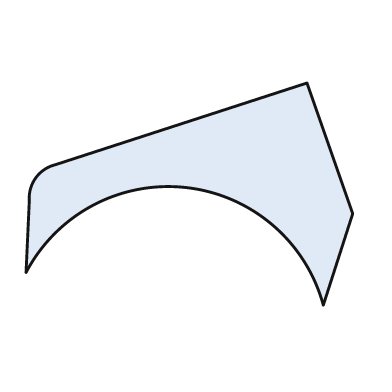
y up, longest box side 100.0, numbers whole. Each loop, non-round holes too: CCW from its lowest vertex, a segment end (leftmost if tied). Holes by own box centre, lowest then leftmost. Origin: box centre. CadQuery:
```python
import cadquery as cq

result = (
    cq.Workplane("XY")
    .moveTo(41.0, -34.0)
    .lineTo(50.0, -6.0)
    .lineTo(36.0, 34.0)
    .lineTo(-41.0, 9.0)
    .threePointArc((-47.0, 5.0), (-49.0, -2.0))
    .lineTo(-50.0, -24.0)
    .threePointArc((-1.0, 2.0), (41.0, -34.0))
    .close()
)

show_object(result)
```